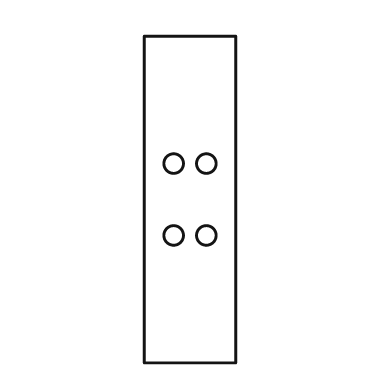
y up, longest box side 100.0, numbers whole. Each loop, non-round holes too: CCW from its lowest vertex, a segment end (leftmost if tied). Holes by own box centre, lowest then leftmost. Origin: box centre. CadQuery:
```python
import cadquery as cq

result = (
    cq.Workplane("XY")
    .moveTo(-14.0, -50.0)
    .lineTo(14.0, -50.0)
    .lineTo(14.0, 50.0)
    .lineTo(-14.0, 50.0)
    .close()
    .moveTo(-5.0, -11.0)
    .circle(3.0)
    .moveTo(5.0, -11.0)
    .circle(3.0)
    .moveTo(-5.0, 11.0)
    .circle(3.0)
    .moveTo(5.0, 11.0)
    .circle(3.0)
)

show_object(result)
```